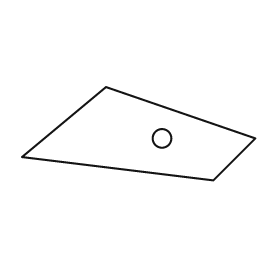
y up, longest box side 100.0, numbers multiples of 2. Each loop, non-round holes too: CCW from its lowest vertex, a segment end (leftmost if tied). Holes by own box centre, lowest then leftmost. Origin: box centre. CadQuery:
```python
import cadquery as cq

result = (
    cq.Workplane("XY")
    .moveTo(32.0, -20.0)
    .lineTo(50.0, -2.0)
    .lineTo(-14.0, 20.0)
    .lineTo(-50.0, -10.0)
    .close()
    .moveTo(10.0, -2.0)
    .circle(4.0)
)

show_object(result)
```